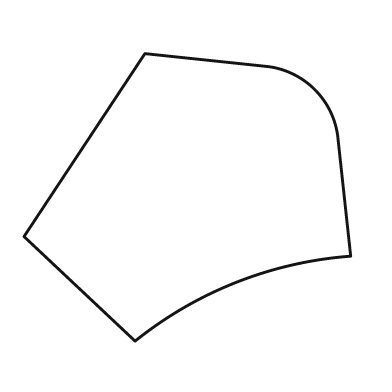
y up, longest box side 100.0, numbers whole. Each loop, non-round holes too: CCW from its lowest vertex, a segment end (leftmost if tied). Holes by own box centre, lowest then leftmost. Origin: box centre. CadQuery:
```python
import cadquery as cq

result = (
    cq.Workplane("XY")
    .moveTo(-16.0, -44.0)
    .threePointArc((15.0, -26.0), (50.0, -18.0))
    .lineTo(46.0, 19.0)
    .threePointArc((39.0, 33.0), (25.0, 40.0))
    .lineTo(-13.0, 44.0)
    .lineTo(-50.0, -12.0)
    .close()
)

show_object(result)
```